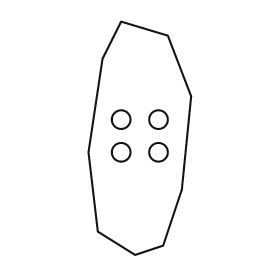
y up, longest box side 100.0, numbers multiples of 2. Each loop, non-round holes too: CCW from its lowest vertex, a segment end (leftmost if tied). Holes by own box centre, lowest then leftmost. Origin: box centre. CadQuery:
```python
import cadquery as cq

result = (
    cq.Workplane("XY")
    .moveTo(-2.0, -50.0)
    .lineTo(10.0, -46.0)
    .lineTo(18.0, -22.0)
    .lineTo(22.0, 18.0)
    .lineTo(12.0, 44.0)
    .lineTo(-8.0, 50.0)
    .lineTo(-16.0, 34.0)
    .lineTo(-22.0, -6.0)
    .lineTo(-18.0, -40.0)
    .close()
    .moveTo(-8.0, -6.0)
    .circle(4.0)
    .moveTo(8.0, -6.0)
    .circle(4.0)
    .moveTo(-8.0, 8.0)
    .circle(4.0)
    .moveTo(8.0, 8.0)
    .circle(4.0)
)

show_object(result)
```